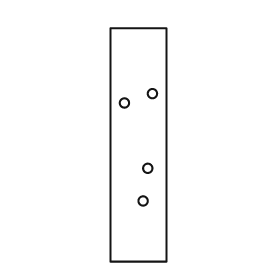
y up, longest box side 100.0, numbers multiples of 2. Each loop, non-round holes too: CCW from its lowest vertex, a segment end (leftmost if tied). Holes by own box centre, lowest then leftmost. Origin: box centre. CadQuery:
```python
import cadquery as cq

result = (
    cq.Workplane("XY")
    .moveTo(-12.0, -50.0)
    .lineTo(12.0, -50.0)
    .lineTo(12.0, 50.0)
    .lineTo(-12.0, 50.0)
    .close()
    .moveTo(2.0, -24.0)
    .circle(2.0)
    .moveTo(4.0, -10.0)
    .circle(2.0)
    .moveTo(-6.0, 18.0)
    .circle(2.0)
    .moveTo(6.0, 22.0)
    .circle(2.0)
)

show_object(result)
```